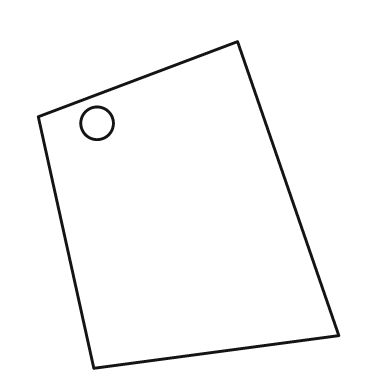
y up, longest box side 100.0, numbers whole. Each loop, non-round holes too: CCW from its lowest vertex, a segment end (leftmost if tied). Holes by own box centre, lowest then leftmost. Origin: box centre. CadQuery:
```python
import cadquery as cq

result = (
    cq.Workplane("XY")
    .moveTo(-29.0, -50.0)
    .lineTo(46.0, -40.0)
    .lineTo(15.0, 50.0)
    .lineTo(-46.0, 27.0)
    .close()
    .moveTo(-28.0, 25.0)
    .circle(5.0)
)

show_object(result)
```